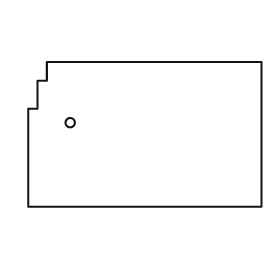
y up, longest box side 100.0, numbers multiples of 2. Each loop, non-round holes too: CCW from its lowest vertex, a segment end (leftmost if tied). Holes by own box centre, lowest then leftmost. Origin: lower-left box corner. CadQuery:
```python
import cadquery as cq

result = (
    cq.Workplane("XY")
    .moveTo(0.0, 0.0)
    .lineTo(100.0, 0.0)
    .lineTo(100.0, 62.0)
    .lineTo(8.0, 62.0)
    .lineTo(8.0, 54.0)
    .lineTo(4.0, 54.0)
    .lineTo(4.0, 42.0)
    .lineTo(0.0, 42.0)
    .close()
    .moveTo(18.0, 36.0)
    .circle(2.0)
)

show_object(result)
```